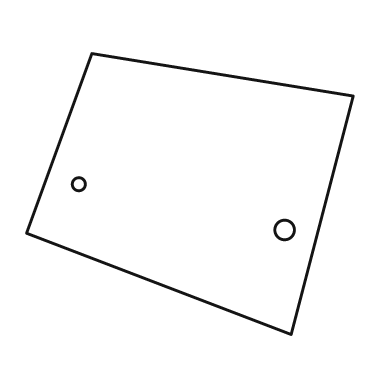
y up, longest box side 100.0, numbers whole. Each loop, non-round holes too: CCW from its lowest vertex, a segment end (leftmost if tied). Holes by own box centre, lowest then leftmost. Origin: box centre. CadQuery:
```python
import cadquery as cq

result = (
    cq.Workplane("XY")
    .moveTo(31.0, -43.0)
    .lineTo(50.0, 30.0)
    .lineTo(-30.0, 43.0)
    .lineTo(-50.0, -12.0)
    .close()
    .moveTo(29.0, -11.0)
    .circle(3.0)
    .moveTo(-34.0, 3.0)
    .circle(2.0)
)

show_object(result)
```